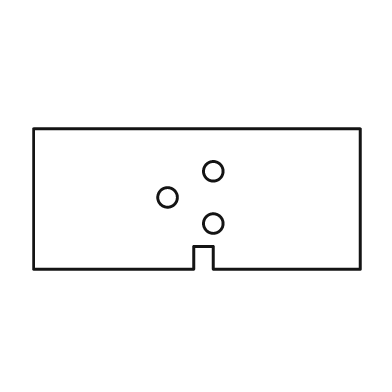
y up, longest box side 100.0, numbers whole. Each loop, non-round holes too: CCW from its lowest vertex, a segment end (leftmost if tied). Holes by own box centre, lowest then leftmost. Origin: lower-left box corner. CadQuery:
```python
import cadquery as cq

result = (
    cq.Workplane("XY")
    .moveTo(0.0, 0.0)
    .lineTo(49.0, 0.0)
    .lineTo(49.0, 7.0)
    .lineTo(55.0, 7.0)
    .lineTo(55.0, 0.0)
    .lineTo(100.0, 0.0)
    .lineTo(100.0, 43.0)
    .lineTo(0.0, 43.0)
    .close()
    .moveTo(55.0, 14.0)
    .circle(3.0)
    .moveTo(41.0, 22.0)
    .circle(3.0)
    .moveTo(55.0, 30.0)
    .circle(3.0)
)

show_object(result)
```